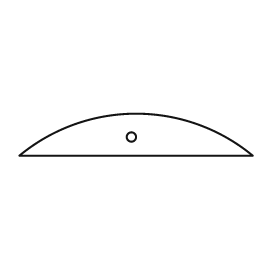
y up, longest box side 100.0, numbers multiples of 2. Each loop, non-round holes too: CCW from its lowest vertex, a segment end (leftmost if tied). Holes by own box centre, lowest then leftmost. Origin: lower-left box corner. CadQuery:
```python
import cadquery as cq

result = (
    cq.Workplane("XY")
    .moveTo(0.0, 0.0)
    .lineTo(100.0, 0.0)
    .threePointArc((50.0, 18.0), (0.0, 0.0))
    .close()
    .moveTo(48.0, 8.0)
    .circle(2.0)
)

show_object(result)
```